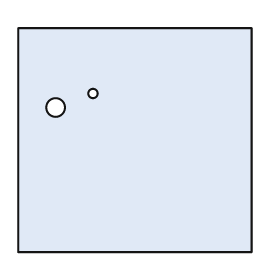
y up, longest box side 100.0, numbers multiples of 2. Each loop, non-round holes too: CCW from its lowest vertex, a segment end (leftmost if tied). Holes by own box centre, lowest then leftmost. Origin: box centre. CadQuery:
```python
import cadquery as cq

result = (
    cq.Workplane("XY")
    .moveTo(-50.0, -48.0)
    .lineTo(50.0, -48.0)
    .lineTo(50.0, 48.0)
    .lineTo(-50.0, 48.0)
    .close()
    .moveTo(-34.0, 14.0)
    .circle(4.0)
    .moveTo(-18.0, 20.0)
    .circle(2.0)
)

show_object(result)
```